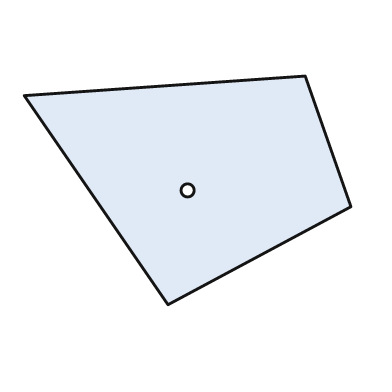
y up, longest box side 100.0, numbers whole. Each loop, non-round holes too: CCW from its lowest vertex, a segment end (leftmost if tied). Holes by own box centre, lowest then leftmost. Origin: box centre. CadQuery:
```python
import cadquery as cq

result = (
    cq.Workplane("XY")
    .moveTo(-6.0, -35.0)
    .lineTo(50.0, -5.0)
    .lineTo(36.0, 35.0)
    .lineTo(-50.0, 29.0)
    .close()
    .moveTo(0.0, 0.0)
    .circle(2.0)
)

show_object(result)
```